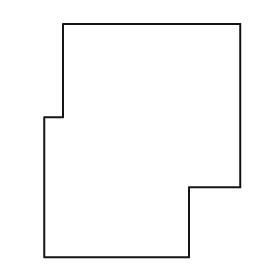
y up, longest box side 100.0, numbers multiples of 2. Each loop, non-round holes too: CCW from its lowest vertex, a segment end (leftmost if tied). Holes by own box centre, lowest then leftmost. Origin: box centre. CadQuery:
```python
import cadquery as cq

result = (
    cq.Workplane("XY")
    .moveTo(-42.0, -50.0)
    .lineTo(20.0, -50.0)
    .lineTo(20.0, -20.0)
    .lineTo(42.0, -20.0)
    .lineTo(42.0, 50.0)
    .lineTo(-34.0, 50.0)
    .lineTo(-34.0, 10.0)
    .lineTo(-42.0, 10.0)
    .close()
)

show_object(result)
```